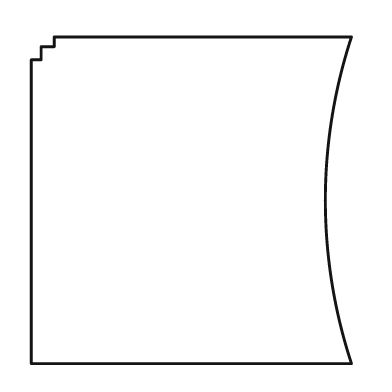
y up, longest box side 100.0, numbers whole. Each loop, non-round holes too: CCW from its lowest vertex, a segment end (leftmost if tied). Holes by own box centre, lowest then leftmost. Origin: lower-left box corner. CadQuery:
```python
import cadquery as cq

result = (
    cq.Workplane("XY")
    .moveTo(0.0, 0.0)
    .lineTo(98.0, 0.0)
    .threePointArc((90.0, 50.0), (98.0, 100.0))
    .lineTo(7.0, 100.0)
    .lineTo(7.0, 97.0)
    .lineTo(3.0, 97.0)
    .lineTo(3.0, 93.0)
    .lineTo(0.0, 93.0)
    .close()
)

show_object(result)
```